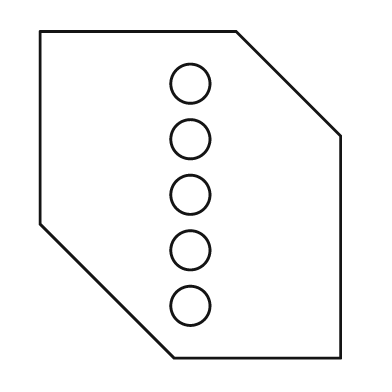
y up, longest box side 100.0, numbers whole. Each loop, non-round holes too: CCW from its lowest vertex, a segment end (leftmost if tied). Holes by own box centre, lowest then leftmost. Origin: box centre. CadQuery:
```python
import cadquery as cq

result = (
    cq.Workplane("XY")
    .moveTo(-5.0, -50.0)
    .lineTo(46.0, -50.0)
    .lineTo(46.0, 18.0)
    .lineTo(14.0, 50.0)
    .lineTo(-46.0, 50.0)
    .lineTo(-46.0, -9.0)
    .close()
    .moveTo(0.0, -34.0)
    .circle(6.0)
    .moveTo(0.0, -17.0)
    .circle(6.0)
    .moveTo(0.0, 0.0)
    .circle(6.0)
    .moveTo(0.0, 17.0)
    .circle(6.0)
    .moveTo(0.0, 34.0)
    .circle(6.0)
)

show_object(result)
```